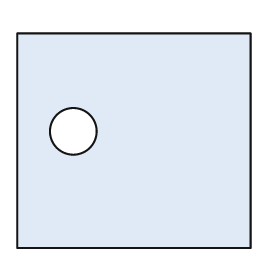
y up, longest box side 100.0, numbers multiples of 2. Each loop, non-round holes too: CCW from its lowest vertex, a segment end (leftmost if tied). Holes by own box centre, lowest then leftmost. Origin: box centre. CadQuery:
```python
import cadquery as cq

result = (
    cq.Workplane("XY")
    .moveTo(-50.0, -46.0)
    .lineTo(50.0, -46.0)
    .lineTo(50.0, 46.0)
    .lineTo(-50.0, 46.0)
    .close()
    .moveTo(-26.0, 4.0)
    .circle(10.0)
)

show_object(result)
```